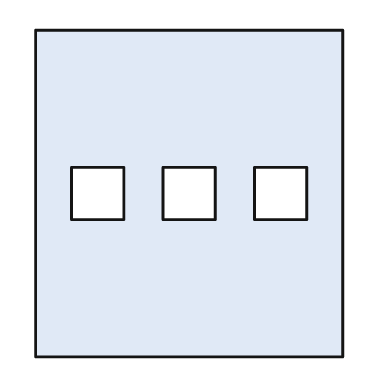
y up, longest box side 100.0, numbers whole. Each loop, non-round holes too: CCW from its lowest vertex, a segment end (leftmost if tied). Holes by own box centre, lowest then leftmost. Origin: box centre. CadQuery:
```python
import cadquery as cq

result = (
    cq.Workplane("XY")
    .moveTo(-47.0, -50.0)
    .lineTo(47.0, -50.0)
    .lineTo(47.0, 50.0)
    .lineTo(-47.0, 50.0)
    .close()
    .moveTo(-36.0, -8.0)
    .lineTo(-20.0, -8.0)
    .lineTo(-20.0, 8.0)
    .lineTo(-36.0, 8.0)
    .close()
    .moveTo(-8.0, -8.0)
    .lineTo(8.0, -8.0)
    .lineTo(8.0, 8.0)
    .lineTo(-8.0, 8.0)
    .close()
    .moveTo(20.0, -8.0)
    .lineTo(36.0, -8.0)
    .lineTo(36.0, 8.0)
    .lineTo(20.0, 8.0)
    .close()
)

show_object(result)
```